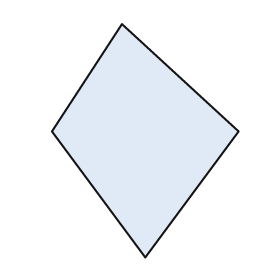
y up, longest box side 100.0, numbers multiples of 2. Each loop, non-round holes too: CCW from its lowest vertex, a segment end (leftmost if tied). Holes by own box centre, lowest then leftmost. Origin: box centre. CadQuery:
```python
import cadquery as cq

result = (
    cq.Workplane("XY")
    .moveTo(0.0, -50.0)
    .lineTo(40.0, 4.0)
    .lineTo(-10.0, 50.0)
    .lineTo(-40.0, 4.0)
    .close()
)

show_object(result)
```